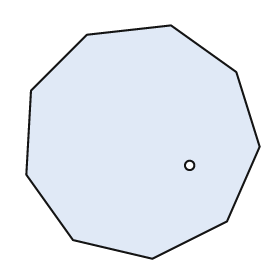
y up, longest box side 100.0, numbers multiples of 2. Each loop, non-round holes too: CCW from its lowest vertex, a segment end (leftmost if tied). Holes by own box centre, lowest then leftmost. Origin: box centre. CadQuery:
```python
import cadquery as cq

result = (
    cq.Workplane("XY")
    .moveTo(4.0, -50.0)
    .lineTo(36.0, -34.0)
    .lineTo(50.0, -2.0)
    .lineTo(40.0, 30.0)
    .lineTo(12.0, 50.0)
    .lineTo(-24.0, 46.0)
    .lineTo(-48.0, 22.0)
    .lineTo(-50.0, -14.0)
    .lineTo(-30.0, -42.0)
    .close()
    .moveTo(20.0, -10.0)
    .circle(2.0)
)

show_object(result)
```